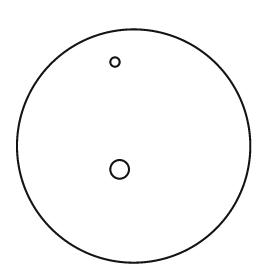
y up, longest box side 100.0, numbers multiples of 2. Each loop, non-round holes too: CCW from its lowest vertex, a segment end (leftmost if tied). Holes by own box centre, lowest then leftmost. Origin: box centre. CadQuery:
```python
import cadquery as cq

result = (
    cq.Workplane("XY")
    .moveTo(0.0, 0.0)
    .circle(50.0)
    .moveTo(-6.0, -10.0)
    .circle(4.0)
    .moveTo(-8.0, 36.0)
    .circle(2.0)
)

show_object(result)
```